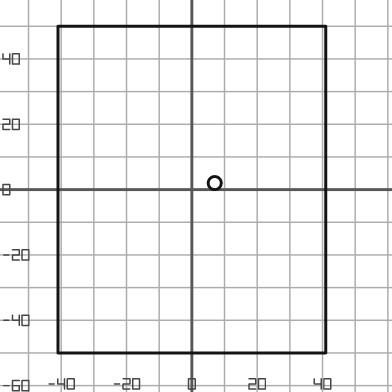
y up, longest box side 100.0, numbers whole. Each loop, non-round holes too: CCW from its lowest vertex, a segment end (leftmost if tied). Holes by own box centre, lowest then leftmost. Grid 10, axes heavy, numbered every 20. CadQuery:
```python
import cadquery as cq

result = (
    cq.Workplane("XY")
    .moveTo(-41.0, -50.0)
    .lineTo(41.0, -50.0)
    .lineTo(41.0, 50.0)
    .lineTo(-41.0, 50.0)
    .close()
    .moveTo(7.0, 2.0)
    .circle(2.0)
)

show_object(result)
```